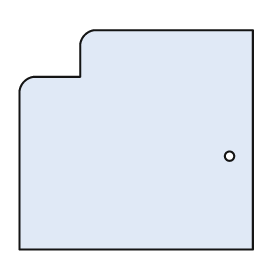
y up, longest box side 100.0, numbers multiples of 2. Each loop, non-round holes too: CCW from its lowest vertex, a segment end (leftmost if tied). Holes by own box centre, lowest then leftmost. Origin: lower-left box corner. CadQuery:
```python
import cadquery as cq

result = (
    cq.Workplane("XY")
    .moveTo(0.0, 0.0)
    .lineTo(100.0, 0.0)
    .lineTo(100.0, 94.0)
    .lineTo(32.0, 94.0)
    .threePointArc((28.0, 92.0), (26.0, 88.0))
    .lineTo(26.0, 74.0)
    .lineTo(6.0, 74.0)
    .threePointArc((2.0, 72.0), (0.0, 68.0))
    .close()
    .moveTo(90.0, 40.0)
    .circle(2.0)
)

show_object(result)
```